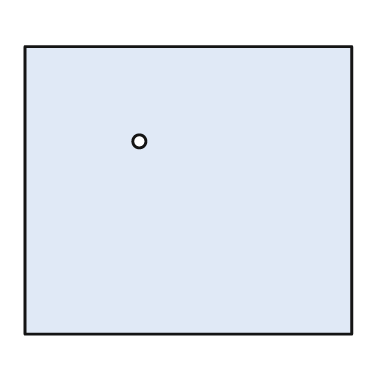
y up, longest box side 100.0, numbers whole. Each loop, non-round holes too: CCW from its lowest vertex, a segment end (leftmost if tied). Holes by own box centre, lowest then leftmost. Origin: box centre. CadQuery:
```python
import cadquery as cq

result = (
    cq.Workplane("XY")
    .moveTo(-50.0, -44.0)
    .lineTo(50.0, -44.0)
    .lineTo(50.0, 44.0)
    .lineTo(-50.0, 44.0)
    .close()
    .moveTo(-15.0, 15.0)
    .circle(2.0)
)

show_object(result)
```